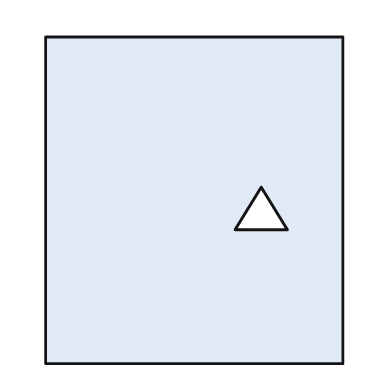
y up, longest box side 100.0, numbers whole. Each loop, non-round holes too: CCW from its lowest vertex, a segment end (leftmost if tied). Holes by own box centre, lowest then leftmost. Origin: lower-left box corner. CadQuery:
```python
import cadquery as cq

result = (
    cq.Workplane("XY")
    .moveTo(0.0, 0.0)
    .lineTo(91.0, 0.0)
    .lineTo(91.0, 100.0)
    .lineTo(0.0, 100.0)
    .close()
    .moveTo(58.0, 41.0)
    .lineTo(74.0, 41.0)
    .lineTo(66.0, 54.0)
    .close()
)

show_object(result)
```